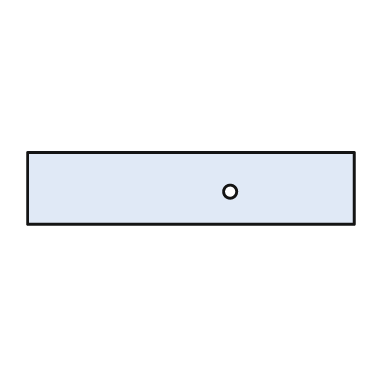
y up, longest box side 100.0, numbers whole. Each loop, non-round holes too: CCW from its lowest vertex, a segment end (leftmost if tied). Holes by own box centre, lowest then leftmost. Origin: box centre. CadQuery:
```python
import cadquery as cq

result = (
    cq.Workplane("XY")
    .moveTo(-50.0, -11.0)
    .lineTo(50.0, -11.0)
    .lineTo(50.0, 11.0)
    .lineTo(-50.0, 11.0)
    .close()
    .moveTo(12.0, -1.0)
    .circle(2.0)
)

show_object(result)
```